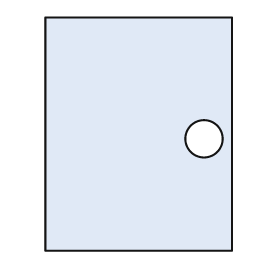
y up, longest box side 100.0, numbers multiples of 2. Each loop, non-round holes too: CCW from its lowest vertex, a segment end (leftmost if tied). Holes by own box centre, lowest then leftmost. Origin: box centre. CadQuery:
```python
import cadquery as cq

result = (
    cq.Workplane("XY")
    .moveTo(-40.0, -50.0)
    .lineTo(40.0, -50.0)
    .lineTo(40.0, 50.0)
    .lineTo(-40.0, 50.0)
    .close()
    .moveTo(28.0, -2.0)
    .circle(8.0)
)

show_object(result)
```